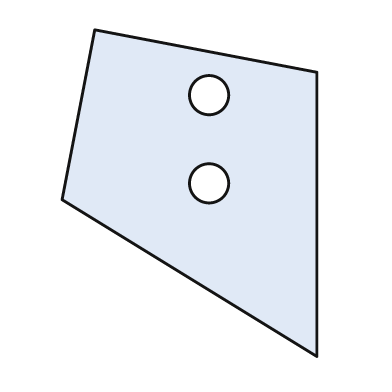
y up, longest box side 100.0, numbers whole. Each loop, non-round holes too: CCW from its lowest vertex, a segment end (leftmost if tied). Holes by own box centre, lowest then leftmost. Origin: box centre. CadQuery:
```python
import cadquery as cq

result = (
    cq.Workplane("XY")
    .moveTo(39.0, -50.0)
    .lineTo(39.0, 37.0)
    .lineTo(-29.0, 50.0)
    .lineTo(-39.0, -2.0)
    .close()
    .moveTo(6.0, 3.0)
    .circle(6.0)
    .moveTo(6.0, 30.0)
    .circle(6.0)
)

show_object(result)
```